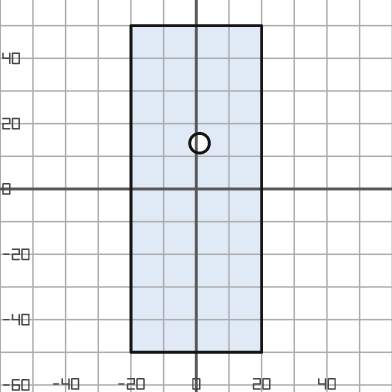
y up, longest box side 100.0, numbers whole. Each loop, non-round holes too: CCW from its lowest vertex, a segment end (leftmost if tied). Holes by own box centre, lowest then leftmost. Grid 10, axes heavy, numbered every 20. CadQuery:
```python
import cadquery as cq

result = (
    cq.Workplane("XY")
    .moveTo(-20.0, -50.0)
    .lineTo(20.0, -50.0)
    .lineTo(20.0, 50.0)
    .lineTo(-20.0, 50.0)
    .close()
    .moveTo(1.0, 14.0)
    .circle(3.0)
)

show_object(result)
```